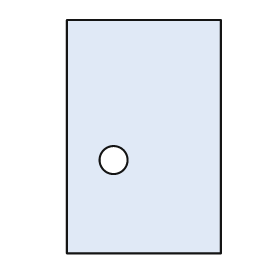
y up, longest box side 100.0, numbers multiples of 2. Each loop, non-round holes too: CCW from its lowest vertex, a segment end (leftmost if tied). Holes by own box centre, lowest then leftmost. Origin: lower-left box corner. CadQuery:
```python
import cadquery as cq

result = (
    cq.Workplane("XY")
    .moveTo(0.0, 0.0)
    .lineTo(66.0, 0.0)
    .lineTo(66.0, 100.0)
    .lineTo(0.0, 100.0)
    .close()
    .moveTo(20.0, 40.0)
    .circle(6.0)
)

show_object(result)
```